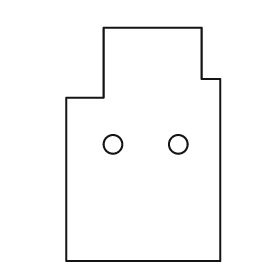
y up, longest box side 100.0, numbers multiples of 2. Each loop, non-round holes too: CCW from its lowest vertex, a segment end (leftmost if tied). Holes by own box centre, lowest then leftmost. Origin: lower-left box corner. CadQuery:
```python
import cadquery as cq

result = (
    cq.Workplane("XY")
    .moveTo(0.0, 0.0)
    .lineTo(66.0, 0.0)
    .lineTo(66.0, 78.0)
    .lineTo(58.0, 78.0)
    .lineTo(58.0, 100.0)
    .lineTo(16.0, 100.0)
    .lineTo(16.0, 70.0)
    .lineTo(0.0, 70.0)
    .close()
    .moveTo(20.0, 50.0)
    .circle(4.0)
    .moveTo(48.0, 50.0)
    .circle(4.0)
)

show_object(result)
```